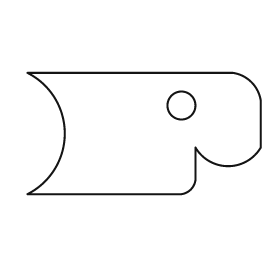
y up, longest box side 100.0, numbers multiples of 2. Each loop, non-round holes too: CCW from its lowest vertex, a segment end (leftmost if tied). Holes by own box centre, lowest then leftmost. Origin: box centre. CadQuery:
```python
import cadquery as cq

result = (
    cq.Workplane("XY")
    .moveTo(-50.0, -26.0)
    .lineTo(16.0, -26.0)
    .threePointArc((20.0, -24.0), (22.0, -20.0))
    .lineTo(22.0, -6.0)
    .threePointArc((36.0, -14.0), (50.0, -6.0))
    .lineTo(50.0, 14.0)
    .threePointArc((46.0, 22.0), (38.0, 26.0))
    .lineTo(-50.0, 26.0)
    .threePointArc((-34.0, 0.0), (-50.0, -26.0))
    .close()
    .moveTo(16.0, 12.0)
    .circle(6.0)
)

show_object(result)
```